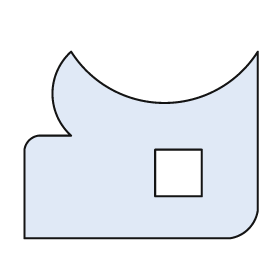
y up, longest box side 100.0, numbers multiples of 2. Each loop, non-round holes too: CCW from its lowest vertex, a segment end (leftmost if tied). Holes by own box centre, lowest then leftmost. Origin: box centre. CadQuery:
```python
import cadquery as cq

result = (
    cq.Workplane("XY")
    .moveTo(-50.0, -40.0)
    .lineTo(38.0, -40.0)
    .threePointArc((46.0, -36.0), (50.0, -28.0))
    .lineTo(50.0, 40.0)
    .threePointArc((10.0, 18.0), (-30.0, 40.0))
    .threePointArc((-38.0, 22.0), (-30.0, 4.0))
    .lineTo(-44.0, 4.0)
    .threePointArc((-48.0, 2.0), (-50.0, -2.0))
    .close()
    .moveTo(6.0, -22.0)
    .lineTo(26.0, -22.0)
    .lineTo(26.0, -2.0)
    .lineTo(6.0, -2.0)
    .close()
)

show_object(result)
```